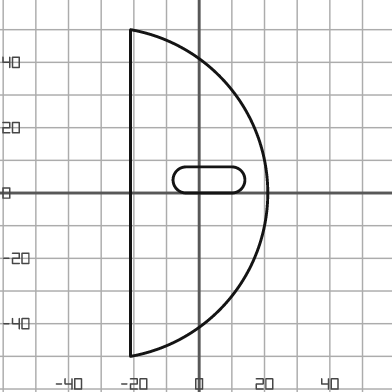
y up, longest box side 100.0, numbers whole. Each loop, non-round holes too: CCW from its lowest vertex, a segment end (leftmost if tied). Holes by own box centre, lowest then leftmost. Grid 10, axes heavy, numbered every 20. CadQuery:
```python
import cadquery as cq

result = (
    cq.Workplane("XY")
    .moveTo(-21.0, -50.0)
    .threePointArc((21.0, 0.0), (-21.0, 50.0))
    .close()
    .moveTo(-4.0, 0.0)
    .lineTo(10.0, 0.0)
    .threePointArc((14.0, 4.0), (10.0, 8.0))
    .lineTo(-4.0, 8.0)
    .threePointArc((-8.0, 4.0), (-4.0, 0.0))
    .close()
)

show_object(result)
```